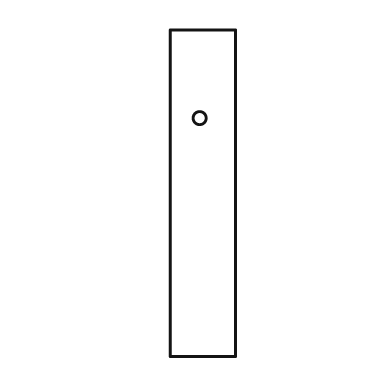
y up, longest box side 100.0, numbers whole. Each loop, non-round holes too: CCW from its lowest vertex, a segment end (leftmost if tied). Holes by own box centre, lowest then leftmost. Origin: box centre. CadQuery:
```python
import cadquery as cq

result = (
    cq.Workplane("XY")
    .moveTo(-10.0, -50.0)
    .lineTo(10.0, -50.0)
    .lineTo(10.0, 50.0)
    .lineTo(-10.0, 50.0)
    .close()
    .moveTo(-1.0, 23.0)
    .circle(2.0)
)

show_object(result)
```